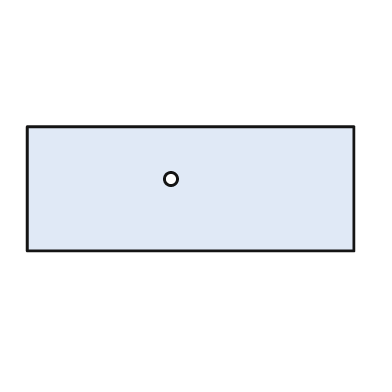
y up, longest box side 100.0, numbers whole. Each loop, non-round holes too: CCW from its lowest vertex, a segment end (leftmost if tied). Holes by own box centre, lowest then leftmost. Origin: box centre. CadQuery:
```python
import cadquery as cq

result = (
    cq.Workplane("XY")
    .moveTo(-50.0, -19.0)
    .lineTo(50.0, -19.0)
    .lineTo(50.0, 19.0)
    .lineTo(-50.0, 19.0)
    .close()
    .moveTo(-6.0, 3.0)
    .circle(2.0)
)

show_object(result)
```